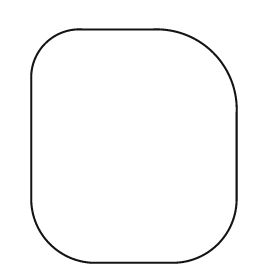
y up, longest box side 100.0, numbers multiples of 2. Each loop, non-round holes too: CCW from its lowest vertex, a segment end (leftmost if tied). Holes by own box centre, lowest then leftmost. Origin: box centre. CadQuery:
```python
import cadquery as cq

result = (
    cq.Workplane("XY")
    .moveTo(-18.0, -50.0)
    .lineTo(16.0, -50.0)
    .threePointArc((36.0, -42.0), (44.0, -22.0))
    .lineTo(44.0, 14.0)
    .threePointArc((34.0, 40.0), (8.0, 50.0))
    .lineTo(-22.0, 50.0)
    .threePointArc((-38.0, 44.0), (-44.0, 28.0))
    .lineTo(-44.0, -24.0)
    .threePointArc((-36.0, -42.0), (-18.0, -50.0))
    .close()
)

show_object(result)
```